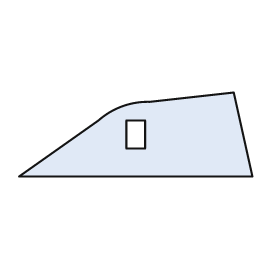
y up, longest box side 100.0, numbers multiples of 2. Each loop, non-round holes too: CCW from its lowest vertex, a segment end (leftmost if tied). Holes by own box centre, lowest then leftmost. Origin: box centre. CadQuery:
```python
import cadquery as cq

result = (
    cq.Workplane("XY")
    .moveTo(-50.0, -18.0)
    .lineTo(50.0, -18.0)
    .lineTo(42.0, 18.0)
    .lineTo(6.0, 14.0)
    .threePointArc((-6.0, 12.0), (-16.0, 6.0))
    .close()
    .moveTo(-4.0, -6.0)
    .lineTo(4.0, -6.0)
    .lineTo(4.0, 6.0)
    .lineTo(-4.0, 6.0)
    .close()
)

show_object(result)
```